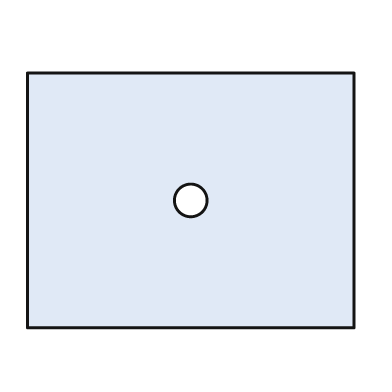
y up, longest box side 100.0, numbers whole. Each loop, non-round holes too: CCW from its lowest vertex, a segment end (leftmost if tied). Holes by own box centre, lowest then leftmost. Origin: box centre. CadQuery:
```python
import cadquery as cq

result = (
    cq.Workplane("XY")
    .moveTo(-50.0, -39.0)
    .lineTo(50.0, -39.0)
    .lineTo(50.0, 39.0)
    .lineTo(-50.0, 39.0)
    .close()
    .moveTo(0.0, 0.0)
    .circle(5.0)
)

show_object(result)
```